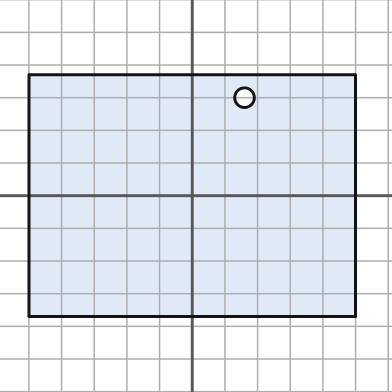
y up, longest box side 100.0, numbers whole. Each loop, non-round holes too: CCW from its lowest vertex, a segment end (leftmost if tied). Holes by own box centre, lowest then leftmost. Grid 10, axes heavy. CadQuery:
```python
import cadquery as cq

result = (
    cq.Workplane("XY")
    .moveTo(-50.0, -37.0)
    .lineTo(50.0, -37.0)
    .lineTo(50.0, 37.0)
    .lineTo(-50.0, 37.0)
    .close()
    .moveTo(16.0, 30.0)
    .circle(3.0)
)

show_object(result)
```